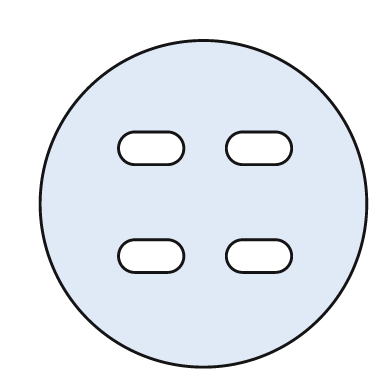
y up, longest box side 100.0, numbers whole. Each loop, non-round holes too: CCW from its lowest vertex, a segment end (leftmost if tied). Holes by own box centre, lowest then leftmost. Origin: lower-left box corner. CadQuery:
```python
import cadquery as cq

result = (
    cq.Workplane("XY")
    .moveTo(50.0, 50.0)
    .circle(50.0)
    .moveTo(29.0, 29.0)
    .lineTo(39.0, 29.0)
    .threePointArc((44.0, 34.0), (39.0, 39.0))
    .lineTo(29.0, 39.0)
    .threePointArc((24.0, 34.0), (29.0, 29.0))
    .close()
    .moveTo(62.0, 29.0)
    .lineTo(72.0, 29.0)
    .threePointArc((77.0, 34.0), (72.0, 39.0))
    .lineTo(62.0, 39.0)
    .threePointArc((57.0, 34.0), (62.0, 29.0))
    .close()
    .moveTo(29.0, 62.0)
    .lineTo(39.0, 62.0)
    .threePointArc((44.0, 67.0), (39.0, 72.0))
    .lineTo(29.0, 72.0)
    .threePointArc((24.0, 67.0), (29.0, 62.0))
    .close()
    .moveTo(62.0, 62.0)
    .lineTo(72.0, 62.0)
    .threePointArc((77.0, 67.0), (72.0, 72.0))
    .lineTo(62.0, 72.0)
    .threePointArc((57.0, 67.0), (62.0, 62.0))
    .close()
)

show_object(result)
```